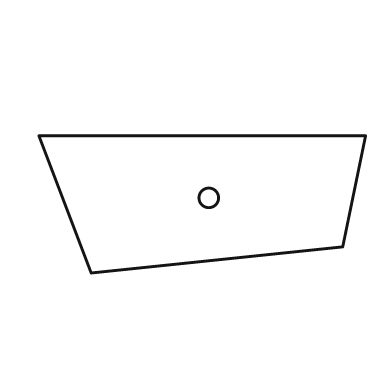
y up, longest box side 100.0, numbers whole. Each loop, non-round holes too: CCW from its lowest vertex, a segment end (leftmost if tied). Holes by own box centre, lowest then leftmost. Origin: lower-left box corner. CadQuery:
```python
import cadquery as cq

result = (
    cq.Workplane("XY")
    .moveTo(16.0, 0.0)
    .lineTo(93.0, 8.0)
    .lineTo(100.0, 42.0)
    .lineTo(0.0, 42.0)
    .close()
    .moveTo(52.0, 23.0)
    .circle(3.0)
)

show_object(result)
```